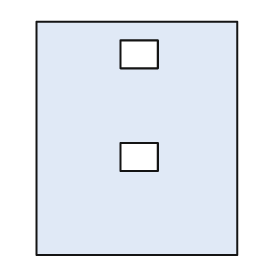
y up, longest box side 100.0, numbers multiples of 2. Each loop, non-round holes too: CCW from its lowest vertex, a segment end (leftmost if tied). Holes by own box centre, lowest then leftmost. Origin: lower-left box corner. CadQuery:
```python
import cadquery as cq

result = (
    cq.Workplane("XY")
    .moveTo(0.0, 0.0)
    .lineTo(86.0, 0.0)
    .lineTo(86.0, 100.0)
    .lineTo(0.0, 100.0)
    .close()
    .moveTo(36.0, 36.0)
    .lineTo(52.0, 36.0)
    .lineTo(52.0, 48.0)
    .lineTo(36.0, 48.0)
    .close()
    .moveTo(36.0, 80.0)
    .lineTo(52.0, 80.0)
    .lineTo(52.0, 92.0)
    .lineTo(36.0, 92.0)
    .close()
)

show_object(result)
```